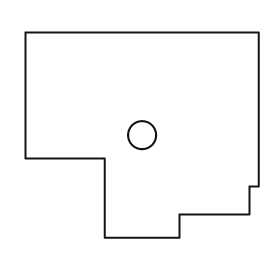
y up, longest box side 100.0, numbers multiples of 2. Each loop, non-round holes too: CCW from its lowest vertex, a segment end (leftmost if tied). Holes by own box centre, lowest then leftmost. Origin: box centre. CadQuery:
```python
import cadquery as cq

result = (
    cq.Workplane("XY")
    .moveTo(-16.0, -44.0)
    .lineTo(16.0, -44.0)
    .lineTo(16.0, -34.0)
    .lineTo(46.0, -34.0)
    .lineTo(46.0, -22.0)
    .lineTo(50.0, -22.0)
    .lineTo(50.0, 44.0)
    .lineTo(-50.0, 44.0)
    .lineTo(-50.0, -10.0)
    .lineTo(-16.0, -10.0)
    .close()
    .moveTo(0.0, 0.0)
    .circle(6.0)
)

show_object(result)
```